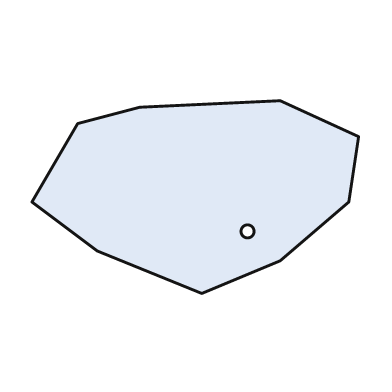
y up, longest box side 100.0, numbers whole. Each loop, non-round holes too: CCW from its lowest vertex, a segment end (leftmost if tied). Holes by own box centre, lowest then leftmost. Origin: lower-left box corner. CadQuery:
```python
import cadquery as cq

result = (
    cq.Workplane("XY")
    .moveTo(52.0, 0.0)
    .lineTo(76.0, 10.0)
    .lineTo(97.0, 28.0)
    .lineTo(100.0, 48.0)
    .lineTo(76.0, 59.0)
    .lineTo(33.0, 57.0)
    .lineTo(14.0, 52.0)
    .lineTo(0.0, 28.0)
    .lineTo(20.0, 13.0)
    .close()
    .moveTo(66.0, 19.0)
    .circle(2.0)
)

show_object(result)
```